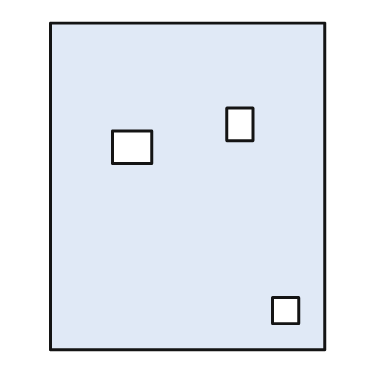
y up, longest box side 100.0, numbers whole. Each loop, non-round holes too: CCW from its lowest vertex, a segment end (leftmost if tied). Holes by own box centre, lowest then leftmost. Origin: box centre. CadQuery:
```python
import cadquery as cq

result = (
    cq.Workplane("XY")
    .moveTo(-42.0, -50.0)
    .lineTo(42.0, -50.0)
    .lineTo(42.0, 50.0)
    .lineTo(-42.0, 50.0)
    .close()
    .moveTo(26.0, -42.0)
    .lineTo(34.0, -42.0)
    .lineTo(34.0, -34.0)
    .lineTo(26.0, -34.0)
    .close()
    .moveTo(-23.0, 7.0)
    .lineTo(-11.0, 7.0)
    .lineTo(-11.0, 17.0)
    .lineTo(-23.0, 17.0)
    .close()
    .moveTo(12.0, 14.0)
    .lineTo(20.0, 14.0)
    .lineTo(20.0, 24.0)
    .lineTo(12.0, 24.0)
    .close()
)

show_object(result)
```